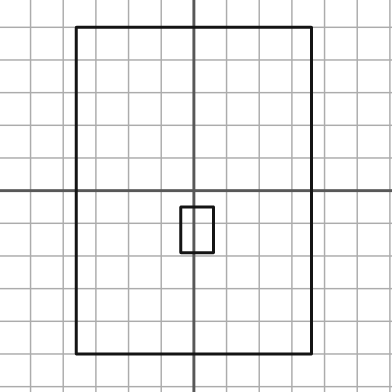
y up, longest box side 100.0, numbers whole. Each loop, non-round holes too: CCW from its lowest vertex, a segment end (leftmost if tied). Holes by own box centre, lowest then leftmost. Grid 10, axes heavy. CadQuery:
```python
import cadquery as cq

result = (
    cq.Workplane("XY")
    .moveTo(-36.0, -50.0)
    .lineTo(36.0, -50.0)
    .lineTo(36.0, 50.0)
    .lineTo(-36.0, 50.0)
    .close()
    .moveTo(-4.0, -19.0)
    .lineTo(6.0, -19.0)
    .lineTo(6.0, -5.0)
    .lineTo(-4.0, -5.0)
    .close()
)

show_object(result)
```